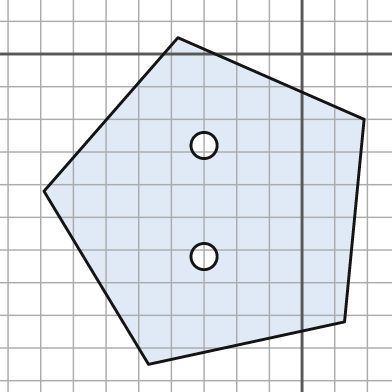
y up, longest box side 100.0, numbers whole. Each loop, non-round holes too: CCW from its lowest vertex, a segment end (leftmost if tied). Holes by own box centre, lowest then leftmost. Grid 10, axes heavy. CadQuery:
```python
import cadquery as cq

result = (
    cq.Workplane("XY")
    .moveTo(-47.0, -95.0)
    .lineTo(13.0, -82.0)
    .lineTo(19.0, -20.0)
    .lineTo(-38.0, 5.0)
    .lineTo(-79.0, -42.0)
    .close()
    .moveTo(-30.0, -62.0)
    .circle(4.0)
    .moveTo(-30.0, -28.0)
    .circle(4.0)
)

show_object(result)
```